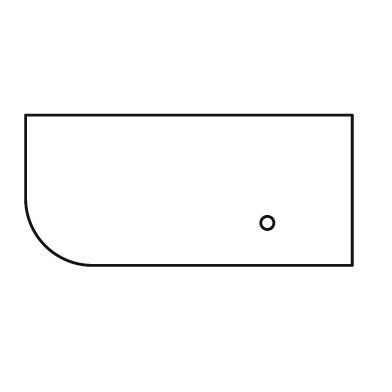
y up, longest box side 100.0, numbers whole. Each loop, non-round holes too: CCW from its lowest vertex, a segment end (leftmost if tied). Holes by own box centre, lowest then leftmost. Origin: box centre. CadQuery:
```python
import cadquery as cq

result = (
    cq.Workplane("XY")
    .moveTo(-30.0, -23.0)
    .lineTo(50.0, -23.0)
    .lineTo(50.0, 23.0)
    .lineTo(-50.0, 23.0)
    .lineTo(-50.0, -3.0)
    .threePointArc((-44.0, -17.0), (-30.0, -23.0))
    .close()
    .moveTo(24.0, -10.0)
    .circle(2.0)
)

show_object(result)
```